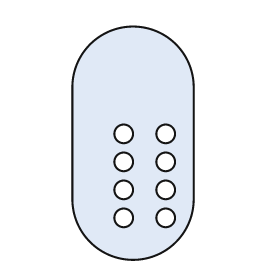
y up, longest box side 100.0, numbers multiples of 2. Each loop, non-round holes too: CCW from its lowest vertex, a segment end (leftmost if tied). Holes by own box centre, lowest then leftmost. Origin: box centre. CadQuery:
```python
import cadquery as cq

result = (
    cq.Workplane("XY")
    .moveTo(-26.0, -24.0)
    .threePointArc((0.0, -50.0), (26.0, -24.0))
    .lineTo(26.0, 24.0)
    .threePointArc((0.0, 50.0), (-26.0, 24.0))
    .close()
    .moveTo(-4.0, -32.0)
    .circle(4.0)
    .moveTo(14.0, -32.0)
    .circle(4.0)
    .moveTo(-4.0, -20.0)
    .circle(4.0)
    .moveTo(14.0, -20.0)
    .circle(4.0)
    .moveTo(-4.0, -8.0)
    .circle(4.0)
    .moveTo(14.0, -8.0)
    .circle(4.0)
    .moveTo(-4.0, 4.0)
    .circle(4.0)
    .moveTo(14.0, 4.0)
    .circle(4.0)
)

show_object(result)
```